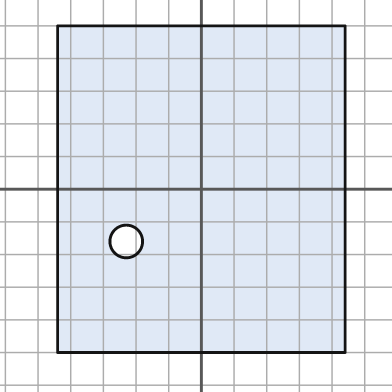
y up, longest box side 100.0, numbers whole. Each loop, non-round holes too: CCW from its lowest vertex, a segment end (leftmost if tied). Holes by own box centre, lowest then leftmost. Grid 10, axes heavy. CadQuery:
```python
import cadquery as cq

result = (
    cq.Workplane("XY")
    .moveTo(-44.0, -50.0)
    .lineTo(44.0, -50.0)
    .lineTo(44.0, 50.0)
    .lineTo(-44.0, 50.0)
    .close()
    .moveTo(-23.0, -16.0)
    .circle(5.0)
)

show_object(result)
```